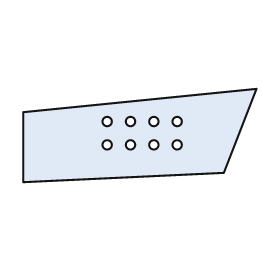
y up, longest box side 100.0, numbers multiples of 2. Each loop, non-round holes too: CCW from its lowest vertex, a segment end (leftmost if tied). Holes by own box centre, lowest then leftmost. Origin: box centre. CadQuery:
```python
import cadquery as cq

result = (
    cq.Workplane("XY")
    .moveTo(-50.0, -20.0)
    .lineTo(36.0, -16.0)
    .lineTo(50.0, 20.0)
    .lineTo(-50.0, 10.0)
    .close()
    .moveTo(-14.0, -4.0)
    .circle(2.0)
    .moveTo(-4.0, -4.0)
    .circle(2.0)
    .moveTo(6.0, -4.0)
    .circle(2.0)
    .moveTo(16.0, -4.0)
    .circle(2.0)
    .moveTo(-14.0, 6.0)
    .circle(2.0)
    .moveTo(-4.0, 6.0)
    .circle(2.0)
    .moveTo(6.0, 6.0)
    .circle(2.0)
    .moveTo(16.0, 6.0)
    .circle(2.0)
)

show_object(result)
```